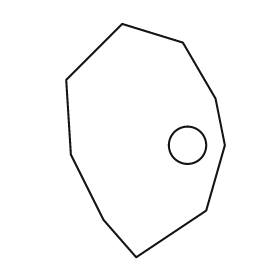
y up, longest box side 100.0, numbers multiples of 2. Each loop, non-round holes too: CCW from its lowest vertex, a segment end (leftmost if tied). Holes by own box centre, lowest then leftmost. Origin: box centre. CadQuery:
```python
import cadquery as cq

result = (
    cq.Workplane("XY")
    .moveTo(-4.0, -50.0)
    .lineTo(26.0, -30.0)
    .lineTo(34.0, -2.0)
    .lineTo(30.0, 18.0)
    .lineTo(16.0, 42.0)
    .lineTo(-10.0, 50.0)
    .lineTo(-34.0, 26.0)
    .lineTo(-32.0, -6.0)
    .lineTo(-18.0, -34.0)
    .close()
    .moveTo(18.0, -2.0)
    .circle(8.0)
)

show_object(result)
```